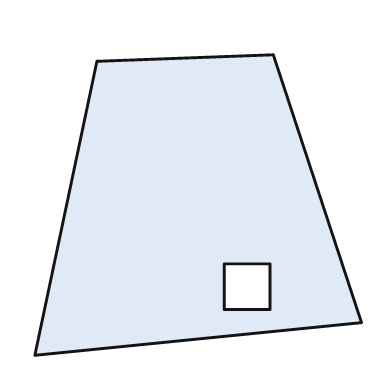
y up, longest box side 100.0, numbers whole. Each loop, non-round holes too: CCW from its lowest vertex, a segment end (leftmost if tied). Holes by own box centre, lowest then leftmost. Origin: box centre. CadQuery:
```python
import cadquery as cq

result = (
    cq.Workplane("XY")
    .moveTo(-50.0, -46.0)
    .lineTo(50.0, -36.0)
    .lineTo(23.0, 46.0)
    .lineTo(-31.0, 44.0)
    .close()
    .moveTo(8.0, -32.0)
    .lineTo(22.0, -32.0)
    .lineTo(22.0, -18.0)
    .lineTo(8.0, -18.0)
    .close()
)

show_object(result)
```